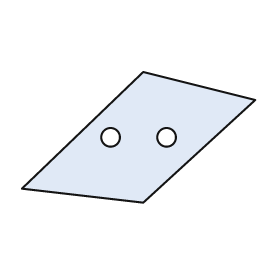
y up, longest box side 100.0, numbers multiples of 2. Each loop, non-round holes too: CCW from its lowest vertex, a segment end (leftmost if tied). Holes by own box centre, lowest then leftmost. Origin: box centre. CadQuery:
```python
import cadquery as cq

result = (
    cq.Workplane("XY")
    .moveTo(2.0, -28.0)
    .lineTo(50.0, 16.0)
    .lineTo(2.0, 28.0)
    .lineTo(-50.0, -22.0)
    .close()
    .moveTo(-12.0, 0.0)
    .circle(4.0)
    .moveTo(12.0, 0.0)
    .circle(4.0)
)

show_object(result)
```